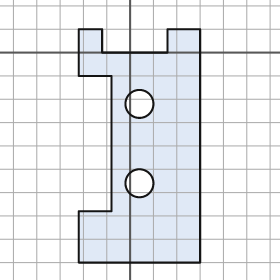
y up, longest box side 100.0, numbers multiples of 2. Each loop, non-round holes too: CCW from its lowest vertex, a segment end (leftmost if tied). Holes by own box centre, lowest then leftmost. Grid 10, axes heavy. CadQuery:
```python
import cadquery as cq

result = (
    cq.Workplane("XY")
    .moveTo(-22.0, -90.0)
    .lineTo(30.0, -90.0)
    .lineTo(30.0, 10.0)
    .lineTo(16.0, 10.0)
    .lineTo(16.0, 0.0)
    .lineTo(-12.0, 0.0)
    .lineTo(-12.0, 10.0)
    .lineTo(-22.0, 10.0)
    .lineTo(-22.0, -10.0)
    .lineTo(-8.0, -10.0)
    .lineTo(-8.0, -68.0)
    .lineTo(-22.0, -68.0)
    .close()
    .moveTo(4.0, -56.0)
    .circle(6.0)
    .moveTo(4.0, -22.0)
    .circle(6.0)
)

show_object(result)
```